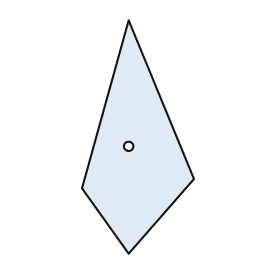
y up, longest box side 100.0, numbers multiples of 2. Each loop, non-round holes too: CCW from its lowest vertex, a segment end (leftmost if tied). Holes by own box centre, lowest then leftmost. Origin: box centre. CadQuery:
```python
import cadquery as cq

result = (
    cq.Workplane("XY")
    .moveTo(-4.0, -50.0)
    .lineTo(24.0, -18.0)
    .lineTo(-4.0, 50.0)
    .lineTo(-24.0, -22.0)
    .close()
    .moveTo(-4.0, -4.0)
    .circle(2.0)
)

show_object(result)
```